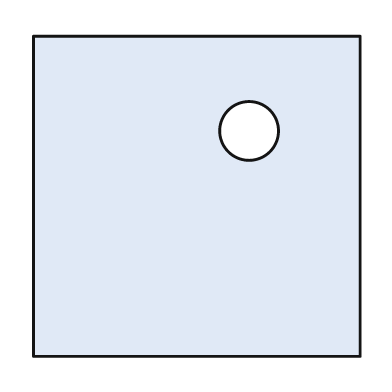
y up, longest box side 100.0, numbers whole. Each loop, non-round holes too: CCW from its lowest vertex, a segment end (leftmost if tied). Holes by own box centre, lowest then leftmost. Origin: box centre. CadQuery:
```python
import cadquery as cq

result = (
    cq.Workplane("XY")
    .moveTo(-50.0, -49.0)
    .lineTo(50.0, -49.0)
    .lineTo(50.0, 49.0)
    .lineTo(-50.0, 49.0)
    .close()
    .moveTo(16.0, 20.0)
    .circle(9.0)
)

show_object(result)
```